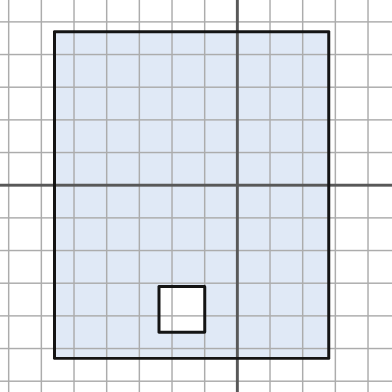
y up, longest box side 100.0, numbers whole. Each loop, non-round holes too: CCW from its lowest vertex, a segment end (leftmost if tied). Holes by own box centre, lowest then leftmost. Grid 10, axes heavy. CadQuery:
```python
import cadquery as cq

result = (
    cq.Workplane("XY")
    .moveTo(-56.0, -53.0)
    .lineTo(28.0, -53.0)
    .lineTo(28.0, 47.0)
    .lineTo(-56.0, 47.0)
    .close()
    .moveTo(-24.0, -45.0)
    .lineTo(-10.0, -45.0)
    .lineTo(-10.0, -31.0)
    .lineTo(-24.0, -31.0)
    .close()
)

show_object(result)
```